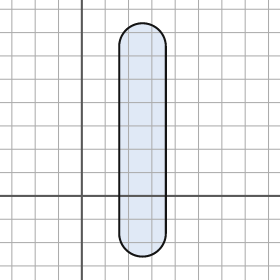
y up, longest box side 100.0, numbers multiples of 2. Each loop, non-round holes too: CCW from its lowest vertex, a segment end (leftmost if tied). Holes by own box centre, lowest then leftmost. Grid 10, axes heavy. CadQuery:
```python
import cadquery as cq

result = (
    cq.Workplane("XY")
    .moveTo(16.0, -16.0)
    .threePointArc((26.0, -26.0), (36.0, -16.0))
    .lineTo(36.0, 64.0)
    .threePointArc((26.0, 74.0), (16.0, 64.0))
    .close()
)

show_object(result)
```